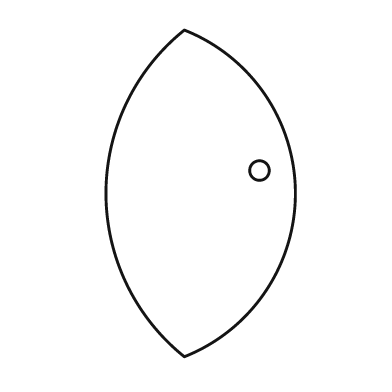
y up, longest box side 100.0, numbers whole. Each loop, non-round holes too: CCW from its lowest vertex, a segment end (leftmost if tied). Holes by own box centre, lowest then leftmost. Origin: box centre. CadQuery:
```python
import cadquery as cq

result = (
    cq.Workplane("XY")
    .moveTo(-5.0, -50.0)
    .threePointArc((29.0, 0.0), (-5.0, 50.0))
    .threePointArc((-29.0, 0.0), (-5.0, -50.0))
    .close()
    .moveTo(18.0, 7.0)
    .circle(3.0)
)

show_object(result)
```